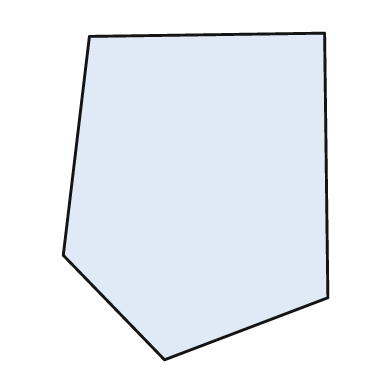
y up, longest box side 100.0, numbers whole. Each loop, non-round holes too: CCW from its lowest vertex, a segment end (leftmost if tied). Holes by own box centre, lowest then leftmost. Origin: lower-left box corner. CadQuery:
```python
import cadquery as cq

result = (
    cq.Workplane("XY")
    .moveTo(31.0, 0.0)
    .lineTo(81.0, 19.0)
    .lineTo(80.0, 100.0)
    .lineTo(8.0, 99.0)
    .lineTo(0.0, 32.0)
    .close()
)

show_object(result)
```